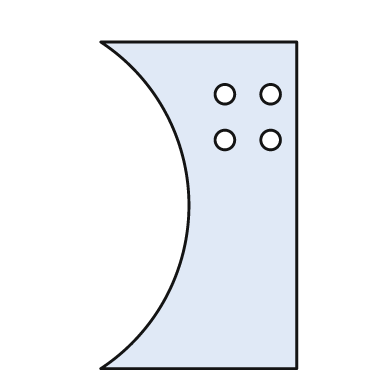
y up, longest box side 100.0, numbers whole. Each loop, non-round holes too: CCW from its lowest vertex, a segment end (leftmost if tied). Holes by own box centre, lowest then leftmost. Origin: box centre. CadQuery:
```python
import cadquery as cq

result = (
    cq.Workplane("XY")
    .moveTo(-30.0, -50.0)
    .lineTo(30.0, -50.0)
    .lineTo(30.0, 50.0)
    .lineTo(-30.0, 50.0)
    .threePointArc((-3.0, 0.0), (-30.0, -50.0))
    .close()
    .moveTo(8.0, 20.0)
    .circle(3.0)
    .moveTo(22.0, 20.0)
    .circle(3.0)
    .moveTo(8.0, 34.0)
    .circle(3.0)
    .moveTo(22.0, 34.0)
    .circle(3.0)
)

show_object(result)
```